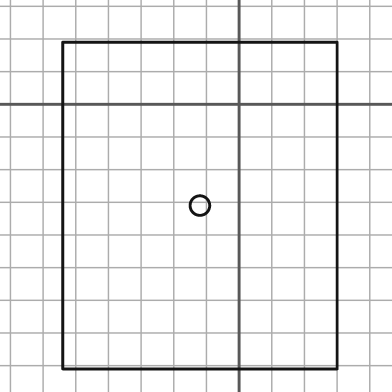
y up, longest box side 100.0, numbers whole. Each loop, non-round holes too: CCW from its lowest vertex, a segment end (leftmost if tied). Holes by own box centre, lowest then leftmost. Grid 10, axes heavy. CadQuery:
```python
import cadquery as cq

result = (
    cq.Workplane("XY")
    .moveTo(-54.0, -81.0)
    .lineTo(30.0, -81.0)
    .lineTo(30.0, 19.0)
    .lineTo(-54.0, 19.0)
    .close()
    .moveTo(-12.0, -31.0)
    .circle(3.0)
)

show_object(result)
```